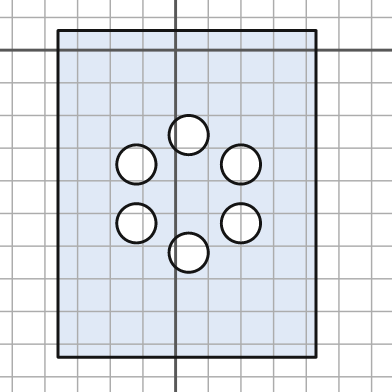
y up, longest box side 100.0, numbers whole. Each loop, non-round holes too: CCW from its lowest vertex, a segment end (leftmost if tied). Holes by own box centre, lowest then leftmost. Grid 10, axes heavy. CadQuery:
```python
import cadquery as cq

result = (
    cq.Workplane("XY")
    .moveTo(-36.0, -94.0)
    .lineTo(43.0, -94.0)
    .lineTo(43.0, 6.0)
    .lineTo(-36.0, 6.0)
    .close()
    .moveTo(4.0, -62.0)
    .circle(6.0)
    .moveTo(-12.0, -53.0)
    .circle(6.0)
    .moveTo(20.0, -53.0)
    .circle(6.0)
    .moveTo(-12.0, -35.0)
    .circle(6.0)
    .moveTo(20.0, -35.0)
    .circle(6.0)
    .moveTo(4.0, -26.0)
    .circle(6.0)
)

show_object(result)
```